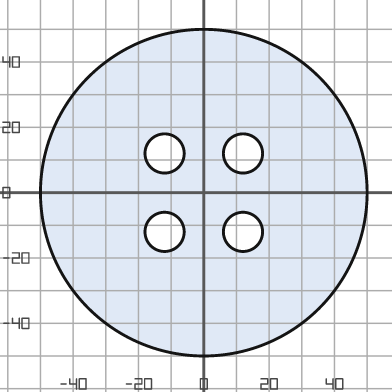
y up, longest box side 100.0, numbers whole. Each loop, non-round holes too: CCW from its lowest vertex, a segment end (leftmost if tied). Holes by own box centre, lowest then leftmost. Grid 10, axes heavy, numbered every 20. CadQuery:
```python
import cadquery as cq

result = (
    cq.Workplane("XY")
    .moveTo(0.0, 0.0)
    .circle(50.0)
    .moveTo(-12.0, -12.0)
    .circle(6.0)
    .moveTo(12.0, -12.0)
    .circle(6.0)
    .moveTo(-12.0, 12.0)
    .circle(6.0)
    .moveTo(12.0, 12.0)
    .circle(6.0)
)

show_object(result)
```